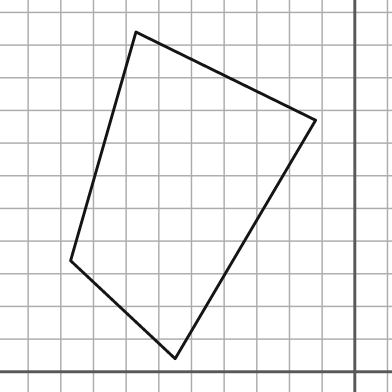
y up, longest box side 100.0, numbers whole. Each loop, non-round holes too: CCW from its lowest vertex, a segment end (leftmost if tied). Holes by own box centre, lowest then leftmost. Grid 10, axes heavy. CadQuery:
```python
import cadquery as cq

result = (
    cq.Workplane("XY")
    .moveTo(-55.0, 4.0)
    .lineTo(-12.0, 77.0)
    .lineTo(-67.0, 104.0)
    .lineTo(-87.0, 34.0)
    .close()
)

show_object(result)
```